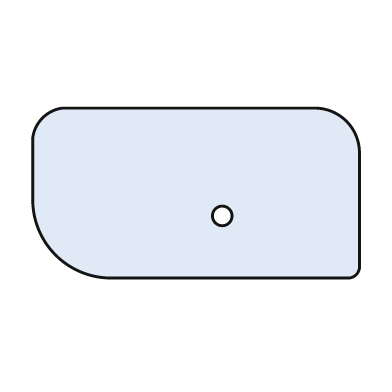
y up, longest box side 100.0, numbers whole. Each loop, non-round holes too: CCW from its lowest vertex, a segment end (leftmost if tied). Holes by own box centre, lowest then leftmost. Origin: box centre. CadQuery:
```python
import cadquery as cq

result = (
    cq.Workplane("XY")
    .moveTo(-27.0, -26.0)
    .lineTo(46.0, -26.0)
    .threePointArc((49.0, -25.0), (50.0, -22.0))
    .lineTo(50.0, 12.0)
    .threePointArc((46.0, 22.0), (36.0, 26.0))
    .lineTo(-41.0, 26.0)
    .threePointArc((-47.0, 23.0), (-50.0, 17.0))
    .lineTo(-50.0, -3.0)
    .threePointArc((-43.0, -19.0), (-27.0, -26.0))
    .close()
    .moveTo(8.0, -7.0)
    .circle(3.0)
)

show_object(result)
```